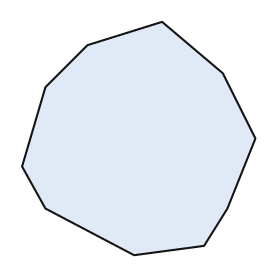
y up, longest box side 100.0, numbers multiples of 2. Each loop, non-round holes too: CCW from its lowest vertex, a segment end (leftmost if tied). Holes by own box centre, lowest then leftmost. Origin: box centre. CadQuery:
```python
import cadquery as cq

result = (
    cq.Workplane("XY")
    .moveTo(-2.0, -50.0)
    .lineTo(28.0, -46.0)
    .lineTo(38.0, -30.0)
    .lineTo(50.0, 0.0)
    .lineTo(36.0, 28.0)
    .lineTo(10.0, 50.0)
    .lineTo(-22.0, 40.0)
    .lineTo(-40.0, 22.0)
    .lineTo(-50.0, -12.0)
    .lineTo(-40.0, -30.0)
    .close()
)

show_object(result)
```